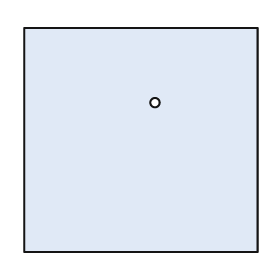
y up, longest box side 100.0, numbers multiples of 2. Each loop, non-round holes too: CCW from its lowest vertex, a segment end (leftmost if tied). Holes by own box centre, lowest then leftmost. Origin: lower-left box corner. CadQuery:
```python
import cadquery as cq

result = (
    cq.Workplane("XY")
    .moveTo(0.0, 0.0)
    .lineTo(100.0, 0.0)
    .lineTo(100.0, 96.0)
    .lineTo(0.0, 96.0)
    .close()
    .moveTo(56.0, 64.0)
    .circle(2.0)
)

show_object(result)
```